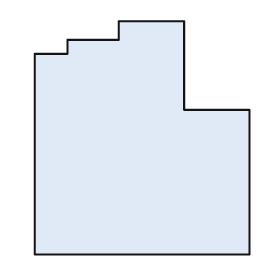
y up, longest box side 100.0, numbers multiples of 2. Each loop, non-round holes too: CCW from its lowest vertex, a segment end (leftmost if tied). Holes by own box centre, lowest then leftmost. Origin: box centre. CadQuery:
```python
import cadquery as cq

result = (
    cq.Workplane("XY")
    .moveTo(-46.0, -50.0)
    .lineTo(46.0, -50.0)
    .lineTo(46.0, 12.0)
    .lineTo(18.0, 12.0)
    .lineTo(18.0, 50.0)
    .lineTo(-10.0, 50.0)
    .lineTo(-10.0, 42.0)
    .lineTo(-32.0, 42.0)
    .lineTo(-32.0, 36.0)
    .lineTo(-46.0, 36.0)
    .close()
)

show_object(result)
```